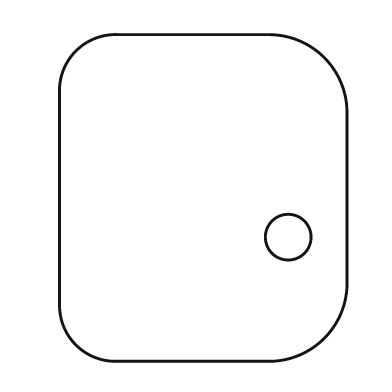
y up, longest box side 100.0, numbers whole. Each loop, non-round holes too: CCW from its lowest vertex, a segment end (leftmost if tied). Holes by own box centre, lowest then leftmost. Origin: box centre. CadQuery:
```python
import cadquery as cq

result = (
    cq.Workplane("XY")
    .moveTo(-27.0, -50.0)
    .lineTo(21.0, -50.0)
    .threePointArc((37.0, -43.0), (44.0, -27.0))
    .lineTo(44.0, 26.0)
    .threePointArc((37.0, 43.0), (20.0, 50.0))
    .lineTo(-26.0, 50.0)
    .threePointArc((-39.0, 45.0), (-44.0, 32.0))
    .lineTo(-44.0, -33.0)
    .threePointArc((-39.0, -45.0), (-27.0, -50.0))
    .close()
    .moveTo(26.0, -12.0)
    .circle(7.0)
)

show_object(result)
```